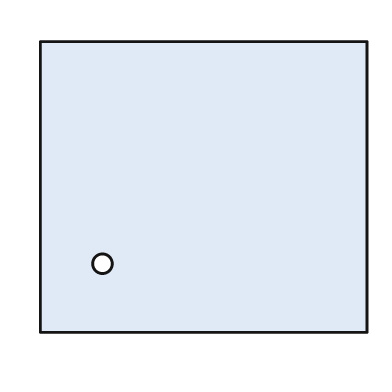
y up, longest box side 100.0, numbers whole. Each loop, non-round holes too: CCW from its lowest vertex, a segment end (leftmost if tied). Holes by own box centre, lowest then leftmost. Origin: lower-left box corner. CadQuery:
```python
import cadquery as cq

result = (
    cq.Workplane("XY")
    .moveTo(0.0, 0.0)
    .lineTo(100.0, 0.0)
    .lineTo(100.0, 89.0)
    .lineTo(0.0, 89.0)
    .close()
    .moveTo(19.0, 21.0)
    .circle(3.0)
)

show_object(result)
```